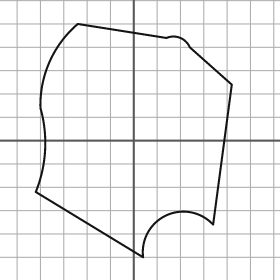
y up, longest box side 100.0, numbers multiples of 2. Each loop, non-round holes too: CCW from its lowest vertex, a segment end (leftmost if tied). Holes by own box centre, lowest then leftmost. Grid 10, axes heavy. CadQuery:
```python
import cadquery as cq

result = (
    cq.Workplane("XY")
    .moveTo(4.0, -50.0)
    .threePointArc((14.0, -32.0), (34.0, -36.0))
    .lineTo(42.0, 24.0)
    .lineTo(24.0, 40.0)
    .threePointArc((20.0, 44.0), (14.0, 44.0))
    .lineTo(-24.0, 50.0)
    .threePointArc((-36.0, 34.0), (-40.0, 14.0))
    .threePointArc((-38.0, -4.0), (-42.0, -22.0))
    .close()
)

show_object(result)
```